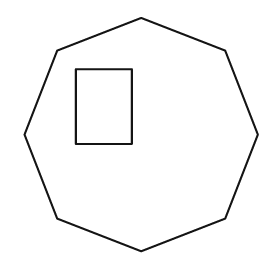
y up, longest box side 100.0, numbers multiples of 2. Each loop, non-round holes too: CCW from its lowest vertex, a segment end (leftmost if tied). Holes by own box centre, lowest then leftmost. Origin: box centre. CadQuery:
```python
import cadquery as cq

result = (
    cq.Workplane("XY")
    .moveTo(0.0, -50.0)
    .lineTo(36.0, -36.0)
    .lineTo(50.0, 0.0)
    .lineTo(36.0, 36.0)
    .lineTo(0.0, 50.0)
    .lineTo(-36.0, 36.0)
    .lineTo(-50.0, 0.0)
    .lineTo(-36.0, -36.0)
    .close()
    .moveTo(-28.0, -4.0)
    .lineTo(-4.0, -4.0)
    .lineTo(-4.0, 28.0)
    .lineTo(-28.0, 28.0)
    .close()
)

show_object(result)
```